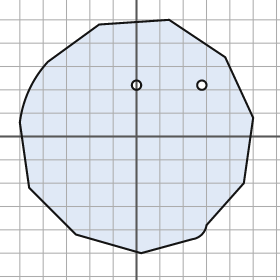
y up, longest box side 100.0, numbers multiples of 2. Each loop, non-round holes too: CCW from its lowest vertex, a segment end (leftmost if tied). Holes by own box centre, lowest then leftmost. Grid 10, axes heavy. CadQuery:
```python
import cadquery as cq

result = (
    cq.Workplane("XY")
    .moveTo(2.0, -50.0)
    .lineTo(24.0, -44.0)
    .threePointArc((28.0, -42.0), (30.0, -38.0))
    .lineTo(46.0, -20.0)
    .lineTo(50.0, 8.0)
    .lineTo(38.0, 34.0)
    .lineTo(14.0, 50.0)
    .lineTo(-16.0, 48.0)
    .lineTo(-38.0, 32.0)
    .threePointArc((-46.0, 20.0), (-50.0, 6.0))
    .lineTo(-46.0, -22.0)
    .lineTo(-26.0, -42.0)
    .close()
    .moveTo(0.0, 22.0)
    .circle(2.0)
    .moveTo(28.0, 22.0)
    .circle(2.0)
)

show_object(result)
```